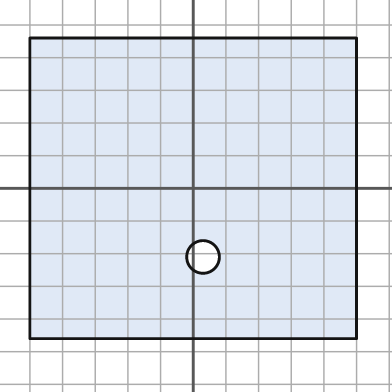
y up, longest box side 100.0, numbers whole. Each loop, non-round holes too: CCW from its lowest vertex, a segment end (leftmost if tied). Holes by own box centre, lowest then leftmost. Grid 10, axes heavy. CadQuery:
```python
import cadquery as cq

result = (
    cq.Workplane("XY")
    .moveTo(-50.0, -46.0)
    .lineTo(50.0, -46.0)
    .lineTo(50.0, 46.0)
    .lineTo(-50.0, 46.0)
    .close()
    .moveTo(3.0, -21.0)
    .circle(5.0)
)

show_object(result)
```